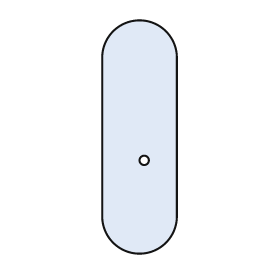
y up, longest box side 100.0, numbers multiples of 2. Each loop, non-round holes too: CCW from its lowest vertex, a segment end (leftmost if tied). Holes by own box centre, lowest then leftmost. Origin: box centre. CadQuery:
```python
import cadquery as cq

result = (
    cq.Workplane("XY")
    .moveTo(-16.0, -34.0)
    .threePointArc((0.0, -50.0), (16.0, -34.0))
    .lineTo(16.0, 34.0)
    .threePointArc((0.0, 50.0), (-16.0, 34.0))
    .close()
    .moveTo(2.0, -10.0)
    .circle(2.0)
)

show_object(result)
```